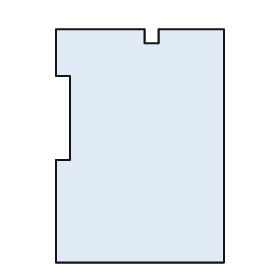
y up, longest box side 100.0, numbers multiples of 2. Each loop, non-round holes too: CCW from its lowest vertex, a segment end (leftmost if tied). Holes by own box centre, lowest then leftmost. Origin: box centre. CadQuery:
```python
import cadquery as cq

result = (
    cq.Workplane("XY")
    .moveTo(-36.0, -50.0)
    .lineTo(36.0, -50.0)
    .lineTo(36.0, 50.0)
    .lineTo(8.0, 50.0)
    .lineTo(8.0, 44.0)
    .lineTo(2.0, 44.0)
    .lineTo(2.0, 50.0)
    .lineTo(-36.0, 50.0)
    .lineTo(-36.0, 30.0)
    .lineTo(-30.0, 30.0)
    .lineTo(-30.0, -6.0)
    .lineTo(-36.0, -6.0)
    .close()
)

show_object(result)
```